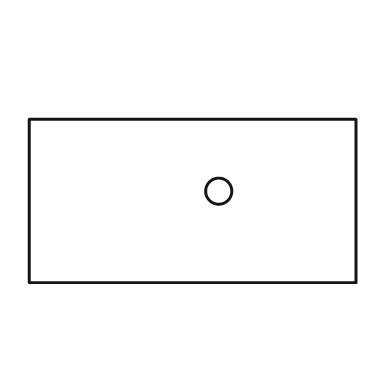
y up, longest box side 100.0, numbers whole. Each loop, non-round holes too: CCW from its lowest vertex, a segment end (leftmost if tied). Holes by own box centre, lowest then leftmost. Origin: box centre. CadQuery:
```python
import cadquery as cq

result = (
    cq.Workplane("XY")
    .moveTo(-50.0, -25.0)
    .lineTo(50.0, -25.0)
    .lineTo(50.0, 25.0)
    .lineTo(-50.0, 25.0)
    .close()
    .moveTo(8.0, 3.0)
    .circle(4.0)
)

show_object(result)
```